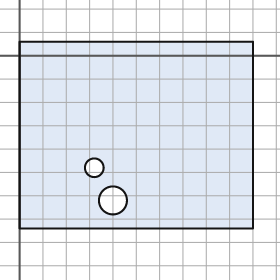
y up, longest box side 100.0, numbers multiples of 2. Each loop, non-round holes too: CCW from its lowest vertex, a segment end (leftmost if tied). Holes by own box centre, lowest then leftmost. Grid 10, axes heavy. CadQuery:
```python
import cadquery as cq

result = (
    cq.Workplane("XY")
    .moveTo(0.0, -74.0)
    .lineTo(100.0, -74.0)
    .lineTo(100.0, 6.0)
    .lineTo(0.0, 6.0)
    .close()
    .moveTo(40.0, -62.0)
    .circle(6.0)
    .moveTo(32.0, -48.0)
    .circle(4.0)
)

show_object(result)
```